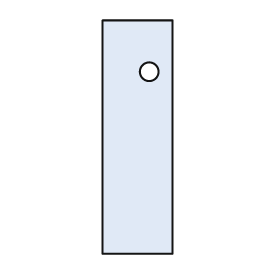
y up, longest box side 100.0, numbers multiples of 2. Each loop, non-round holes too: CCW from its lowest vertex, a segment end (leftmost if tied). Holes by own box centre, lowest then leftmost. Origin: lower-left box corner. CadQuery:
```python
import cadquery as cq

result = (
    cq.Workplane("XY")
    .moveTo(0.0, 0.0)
    .lineTo(30.0, 0.0)
    .lineTo(30.0, 100.0)
    .lineTo(0.0, 100.0)
    .close()
    .moveTo(20.0, 78.0)
    .circle(4.0)
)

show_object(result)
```